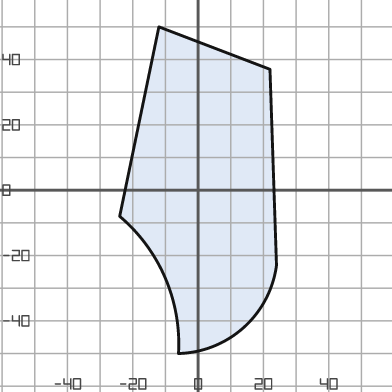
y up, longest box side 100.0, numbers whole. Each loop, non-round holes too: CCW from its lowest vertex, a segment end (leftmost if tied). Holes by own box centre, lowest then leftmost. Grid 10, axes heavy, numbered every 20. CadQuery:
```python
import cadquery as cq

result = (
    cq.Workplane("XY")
    .moveTo(-6.0, -50.0)
    .threePointArc((14.0, -42.0), (24.0, -23.0))
    .lineTo(22.0, 37.0)
    .lineTo(-12.0, 50.0)
    .lineTo(-24.0, -8.0)
    .threePointArc((-10.0, -27.0), (-6.0, -50.0))
    .close()
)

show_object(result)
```